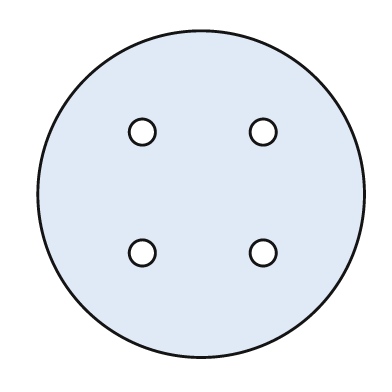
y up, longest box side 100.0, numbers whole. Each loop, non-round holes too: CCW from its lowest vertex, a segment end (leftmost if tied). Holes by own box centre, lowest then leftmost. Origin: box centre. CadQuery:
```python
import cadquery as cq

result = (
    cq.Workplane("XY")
    .moveTo(0.0, 0.0)
    .circle(50.0)
    .moveTo(-18.0, -18.0)
    .circle(4.0)
    .moveTo(19.0, -18.0)
    .circle(4.0)
    .moveTo(-18.0, 19.0)
    .circle(4.0)
    .moveTo(19.0, 19.0)
    .circle(4.0)
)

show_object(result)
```